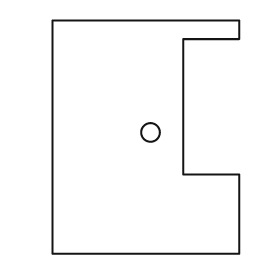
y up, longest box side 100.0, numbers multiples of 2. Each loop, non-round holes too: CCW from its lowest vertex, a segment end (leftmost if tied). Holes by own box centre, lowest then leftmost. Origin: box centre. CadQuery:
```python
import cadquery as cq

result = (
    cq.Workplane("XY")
    .moveTo(-40.0, -50.0)
    .lineTo(40.0, -50.0)
    .lineTo(40.0, -16.0)
    .lineTo(16.0, -16.0)
    .lineTo(16.0, 42.0)
    .lineTo(40.0, 42.0)
    .lineTo(40.0, 50.0)
    .lineTo(-40.0, 50.0)
    .close()
    .moveTo(2.0, 2.0)
    .circle(4.0)
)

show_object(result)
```